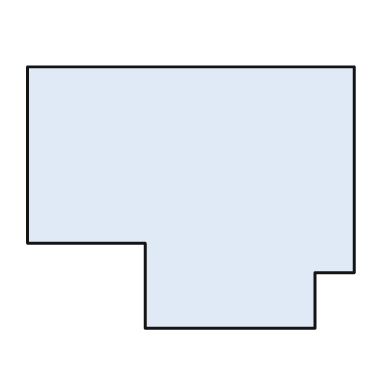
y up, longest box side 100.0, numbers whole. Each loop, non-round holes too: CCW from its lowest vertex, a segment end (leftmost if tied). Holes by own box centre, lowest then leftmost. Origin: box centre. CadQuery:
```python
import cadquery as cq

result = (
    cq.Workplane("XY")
    .moveTo(-14.0, -40.0)
    .lineTo(38.0, -40.0)
    .lineTo(38.0, -23.0)
    .lineTo(50.0, -23.0)
    .lineTo(50.0, 40.0)
    .lineTo(-50.0, 40.0)
    .lineTo(-50.0, -14.0)
    .lineTo(-14.0, -14.0)
    .close()
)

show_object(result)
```